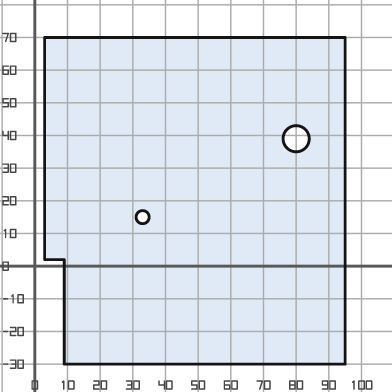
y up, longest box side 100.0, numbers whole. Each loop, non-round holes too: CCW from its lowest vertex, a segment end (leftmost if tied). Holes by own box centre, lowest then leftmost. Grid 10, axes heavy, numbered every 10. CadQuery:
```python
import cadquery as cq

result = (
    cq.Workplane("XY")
    .moveTo(9.0, -30.0)
    .lineTo(95.0, -30.0)
    .lineTo(95.0, 70.0)
    .lineTo(3.0, 70.0)
    .lineTo(3.0, 2.0)
    .lineTo(9.0, 2.0)
    .close()
    .moveTo(33.0, 15.0)
    .circle(2.0)
    .moveTo(80.0, 39.0)
    .circle(4.0)
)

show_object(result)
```